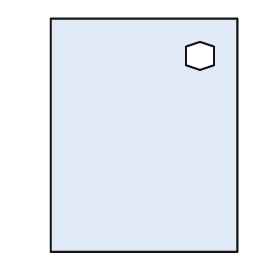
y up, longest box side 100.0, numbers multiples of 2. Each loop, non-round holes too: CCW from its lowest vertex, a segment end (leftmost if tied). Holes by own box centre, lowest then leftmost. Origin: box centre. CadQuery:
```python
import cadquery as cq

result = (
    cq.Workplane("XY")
    .moveTo(-40.0, -50.0)
    .lineTo(40.0, -50.0)
    .lineTo(40.0, 50.0)
    .lineTo(-40.0, 50.0)
    .close()
    .moveTo(24.0, 28.0)
    .lineTo(30.0, 30.0)
    .lineTo(30.0, 38.0)
    .lineTo(24.0, 40.0)
    .lineTo(18.0, 38.0)
    .lineTo(18.0, 30.0)
    .close()
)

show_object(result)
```